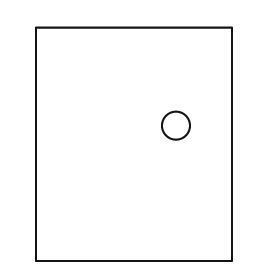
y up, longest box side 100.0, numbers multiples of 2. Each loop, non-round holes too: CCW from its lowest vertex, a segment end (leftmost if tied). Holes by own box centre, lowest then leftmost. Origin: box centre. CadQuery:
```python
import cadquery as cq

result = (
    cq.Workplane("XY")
    .moveTo(-42.0, -50.0)
    .lineTo(42.0, -50.0)
    .lineTo(42.0, 50.0)
    .lineTo(-42.0, 50.0)
    .close()
    .moveTo(18.0, 8.0)
    .circle(6.0)
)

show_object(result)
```